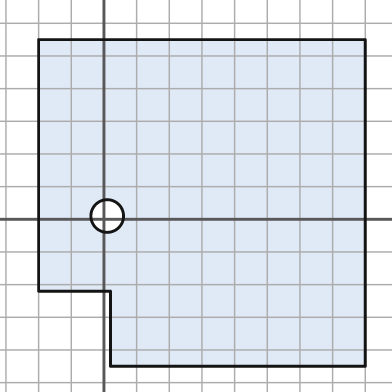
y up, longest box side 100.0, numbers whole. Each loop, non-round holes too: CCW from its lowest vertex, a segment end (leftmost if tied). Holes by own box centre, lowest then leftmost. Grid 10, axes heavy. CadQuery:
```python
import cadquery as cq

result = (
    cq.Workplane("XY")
    .moveTo(2.0, -45.0)
    .lineTo(80.0, -45.0)
    .lineTo(80.0, 55.0)
    .lineTo(-20.0, 55.0)
    .lineTo(-20.0, -22.0)
    .lineTo(2.0, -22.0)
    .close()
    .moveTo(1.0, 1.0)
    .circle(5.0)
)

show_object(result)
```